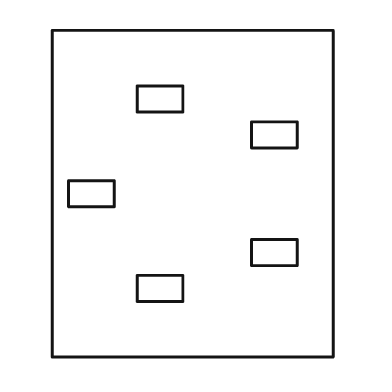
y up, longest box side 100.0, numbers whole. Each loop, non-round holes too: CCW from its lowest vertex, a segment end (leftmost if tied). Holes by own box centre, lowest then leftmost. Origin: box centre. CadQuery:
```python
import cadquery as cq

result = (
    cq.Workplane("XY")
    .moveTo(-43.0, -50.0)
    .lineTo(43.0, -50.0)
    .lineTo(43.0, 50.0)
    .lineTo(-43.0, 50.0)
    .close()
    .moveTo(-17.0, -33.0)
    .lineTo(-3.0, -33.0)
    .lineTo(-3.0, -25.0)
    .lineTo(-17.0, -25.0)
    .close()
    .moveTo(18.0, -22.0)
    .lineTo(32.0, -22.0)
    .lineTo(32.0, -14.0)
    .lineTo(18.0, -14.0)
    .close()
    .moveTo(-38.0, -4.0)
    .lineTo(-24.0, -4.0)
    .lineTo(-24.0, 4.0)
    .lineTo(-38.0, 4.0)
    .close()
    .moveTo(18.0, 14.0)
    .lineTo(32.0, 14.0)
    .lineTo(32.0, 22.0)
    .lineTo(18.0, 22.0)
    .close()
    .moveTo(-17.0, 25.0)
    .lineTo(-3.0, 25.0)
    .lineTo(-3.0, 33.0)
    .lineTo(-17.0, 33.0)
    .close()
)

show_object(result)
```